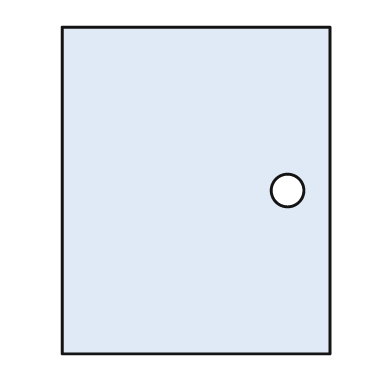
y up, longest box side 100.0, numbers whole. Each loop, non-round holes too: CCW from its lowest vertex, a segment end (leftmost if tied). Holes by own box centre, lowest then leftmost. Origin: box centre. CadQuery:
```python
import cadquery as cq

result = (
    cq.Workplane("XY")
    .moveTo(-41.0, -50.0)
    .lineTo(41.0, -50.0)
    .lineTo(41.0, 50.0)
    .lineTo(-41.0, 50.0)
    .close()
    .moveTo(28.0, 0.0)
    .circle(5.0)
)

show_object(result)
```